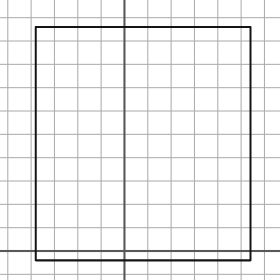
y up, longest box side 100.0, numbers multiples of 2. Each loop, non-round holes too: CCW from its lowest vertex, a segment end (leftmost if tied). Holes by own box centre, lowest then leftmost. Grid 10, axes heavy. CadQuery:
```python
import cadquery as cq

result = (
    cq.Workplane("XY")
    .moveTo(-38.0, -4.0)
    .lineTo(54.0, -4.0)
    .lineTo(54.0, 96.0)
    .lineTo(-38.0, 96.0)
    .close()
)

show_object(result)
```